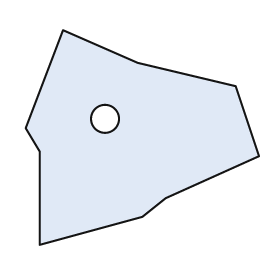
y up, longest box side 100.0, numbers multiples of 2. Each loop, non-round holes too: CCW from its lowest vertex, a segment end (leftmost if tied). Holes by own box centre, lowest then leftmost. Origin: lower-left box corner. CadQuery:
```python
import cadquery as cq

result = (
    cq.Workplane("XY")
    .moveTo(6.0, 0.0)
    .lineTo(50.0, 12.0)
    .lineTo(60.0, 20.0)
    .lineTo(100.0, 38.0)
    .lineTo(90.0, 68.0)
    .lineTo(48.0, 78.0)
    .lineTo(16.0, 92.0)
    .lineTo(0.0, 50.0)
    .lineTo(6.0, 40.0)
    .close()
    .moveTo(34.0, 54.0)
    .circle(6.0)
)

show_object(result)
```